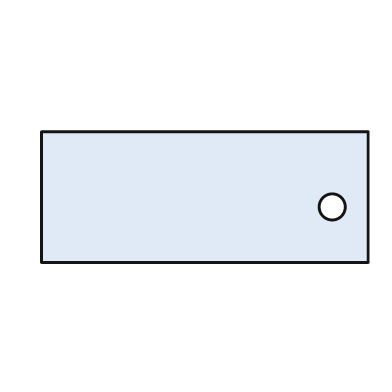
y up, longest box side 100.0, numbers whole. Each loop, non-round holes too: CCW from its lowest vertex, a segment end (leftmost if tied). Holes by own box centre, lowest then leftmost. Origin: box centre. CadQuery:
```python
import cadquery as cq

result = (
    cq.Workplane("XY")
    .moveTo(-50.0, -20.0)
    .lineTo(50.0, -20.0)
    .lineTo(50.0, 20.0)
    .lineTo(-50.0, 20.0)
    .close()
    .moveTo(39.0, -3.0)
    .circle(4.0)
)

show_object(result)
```